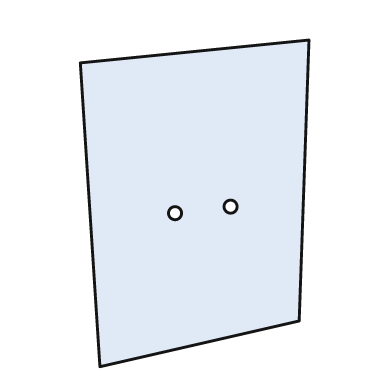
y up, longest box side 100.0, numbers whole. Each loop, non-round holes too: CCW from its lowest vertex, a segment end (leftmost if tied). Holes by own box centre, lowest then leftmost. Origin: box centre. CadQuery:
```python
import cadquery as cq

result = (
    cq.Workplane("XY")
    .moveTo(-29.0, -50.0)
    .lineTo(32.0, -36.0)
    .lineTo(35.0, 50.0)
    .lineTo(-35.0, 43.0)
    .close()
    .moveTo(-6.0, -3.0)
    .circle(2.0)
    .moveTo(11.0, -1.0)
    .circle(2.0)
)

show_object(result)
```